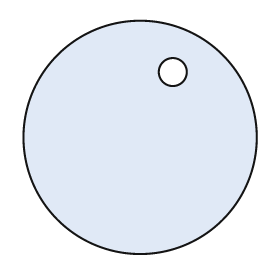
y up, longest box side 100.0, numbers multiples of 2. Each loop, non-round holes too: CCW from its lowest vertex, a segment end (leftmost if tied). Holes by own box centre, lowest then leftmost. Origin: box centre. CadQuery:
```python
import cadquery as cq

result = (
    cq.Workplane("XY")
    .moveTo(0.0, 0.0)
    .circle(50.0)
    .moveTo(14.0, 28.0)
    .circle(6.0)
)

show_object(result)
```